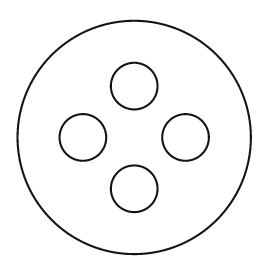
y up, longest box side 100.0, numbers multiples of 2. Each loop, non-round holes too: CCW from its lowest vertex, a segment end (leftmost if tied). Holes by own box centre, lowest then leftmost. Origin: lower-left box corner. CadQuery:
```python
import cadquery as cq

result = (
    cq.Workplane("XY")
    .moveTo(50.0, 50.0)
    .circle(50.0)
    .moveTo(50.0, 28.0)
    .circle(10.0)
    .moveTo(28.0, 50.0)
    .circle(10.0)
    .moveTo(72.0, 50.0)
    .circle(10.0)
    .moveTo(50.0, 72.0)
    .circle(10.0)
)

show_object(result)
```